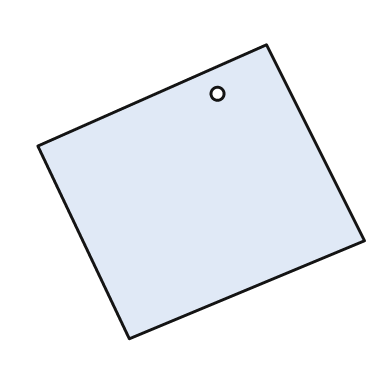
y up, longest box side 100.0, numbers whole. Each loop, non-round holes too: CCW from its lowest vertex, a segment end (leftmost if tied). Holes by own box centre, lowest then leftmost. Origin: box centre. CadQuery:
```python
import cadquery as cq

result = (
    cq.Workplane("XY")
    .moveTo(-22.0, -45.0)
    .lineTo(50.0, -15.0)
    .lineTo(20.0, 45.0)
    .lineTo(-50.0, 14.0)
    .close()
    .moveTo(5.0, 30.0)
    .circle(2.0)
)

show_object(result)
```